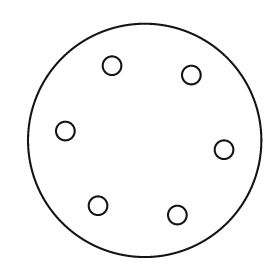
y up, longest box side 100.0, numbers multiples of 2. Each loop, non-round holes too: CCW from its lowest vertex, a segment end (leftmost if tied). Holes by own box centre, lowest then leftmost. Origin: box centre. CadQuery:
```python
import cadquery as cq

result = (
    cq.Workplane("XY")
    .moveTo(0.0, 0.0)
    .circle(50.0)
    .moveTo(14.0, -32.0)
    .circle(4.0)
    .moveTo(-20.0, -28.0)
    .circle(4.0)
    .moveTo(34.0, -4.0)
    .circle(4.0)
    .moveTo(-34.0, 4.0)
    .circle(4.0)
    .moveTo(20.0, 28.0)
    .circle(4.0)
    .moveTo(-14.0, 32.0)
    .circle(4.0)
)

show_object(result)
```